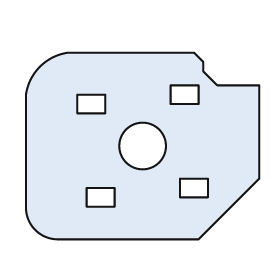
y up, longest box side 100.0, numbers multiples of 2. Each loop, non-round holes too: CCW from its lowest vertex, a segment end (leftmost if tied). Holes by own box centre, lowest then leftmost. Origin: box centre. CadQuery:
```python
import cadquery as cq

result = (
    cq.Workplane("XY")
    .moveTo(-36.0, -40.0)
    .lineTo(24.0, -40.0)
    .lineTo(50.0, -14.0)
    .lineTo(50.0, 26.0)
    .lineTo(32.0, 26.0)
    .lineTo(26.0, 32.0)
    .lineTo(26.0, 36.0)
    .lineTo(22.0, 40.0)
    .lineTo(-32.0, 40.0)
    .threePointArc((-44.0, 34.0), (-50.0, 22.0))
    .lineTo(-50.0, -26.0)
    .threePointArc((-46.0, -36.0), (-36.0, -40.0))
    .close()
    .moveTo(-24.0, -26.0)
    .lineTo(-12.0, -26.0)
    .lineTo(-12.0, -18.0)
    .lineTo(-24.0, -18.0)
    .close()
    .moveTo(16.0, -22.0)
    .lineTo(28.0, -22.0)
    .lineTo(28.0, -14.0)
    .lineTo(16.0, -14.0)
    .close()
    .moveTo(0.0, 0.0)
    .circle(10.0)
    .moveTo(-28.0, 14.0)
    .lineTo(-16.0, 14.0)
    .lineTo(-16.0, 22.0)
    .lineTo(-28.0, 22.0)
    .close()
    .moveTo(12.0, 18.0)
    .lineTo(24.0, 18.0)
    .lineTo(24.0, 26.0)
    .lineTo(12.0, 26.0)
    .close()
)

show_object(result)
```